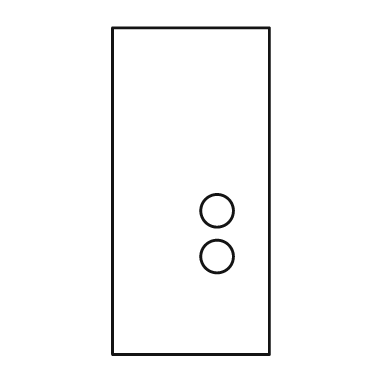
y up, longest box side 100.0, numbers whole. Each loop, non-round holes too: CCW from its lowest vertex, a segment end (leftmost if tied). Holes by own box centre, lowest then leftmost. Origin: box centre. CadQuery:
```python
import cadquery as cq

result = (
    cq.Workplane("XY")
    .moveTo(-24.0, -50.0)
    .lineTo(24.0, -50.0)
    .lineTo(24.0, 50.0)
    .lineTo(-24.0, 50.0)
    .close()
    .moveTo(8.0, -20.0)
    .circle(5.0)
    .moveTo(8.0, -6.0)
    .circle(5.0)
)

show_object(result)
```